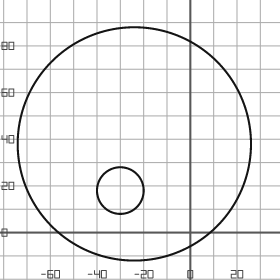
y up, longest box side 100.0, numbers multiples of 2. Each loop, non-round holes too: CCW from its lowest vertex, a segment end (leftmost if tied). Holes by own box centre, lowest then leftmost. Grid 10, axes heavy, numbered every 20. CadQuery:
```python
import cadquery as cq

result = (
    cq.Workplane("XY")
    .moveTo(-24.0, 38.0)
    .circle(50.0)
    .moveTo(-30.0, 18.0)
    .circle(10.0)
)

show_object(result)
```